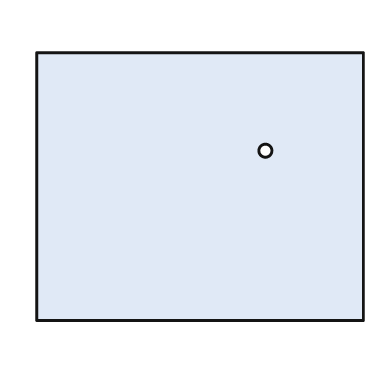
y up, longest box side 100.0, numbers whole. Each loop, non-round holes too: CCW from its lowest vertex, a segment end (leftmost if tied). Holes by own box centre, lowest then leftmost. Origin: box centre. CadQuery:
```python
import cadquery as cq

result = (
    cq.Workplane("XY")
    .moveTo(-50.0, -41.0)
    .lineTo(50.0, -41.0)
    .lineTo(50.0, 41.0)
    .lineTo(-50.0, 41.0)
    .close()
    .moveTo(20.0, 11.0)
    .circle(2.0)
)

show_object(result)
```